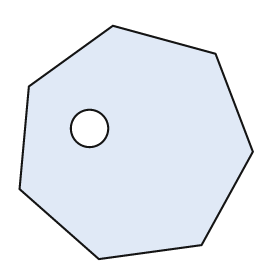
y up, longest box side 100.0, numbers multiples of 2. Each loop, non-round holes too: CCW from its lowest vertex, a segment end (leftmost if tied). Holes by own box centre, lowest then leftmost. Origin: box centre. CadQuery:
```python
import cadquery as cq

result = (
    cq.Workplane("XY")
    .moveTo(-16.0, -50.0)
    .lineTo(28.0, -44.0)
    .lineTo(50.0, -4.0)
    .lineTo(34.0, 38.0)
    .lineTo(-10.0, 50.0)
    .lineTo(-46.0, 24.0)
    .lineTo(-50.0, -20.0)
    .close()
    .moveTo(-20.0, 6.0)
    .circle(8.0)
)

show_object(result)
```